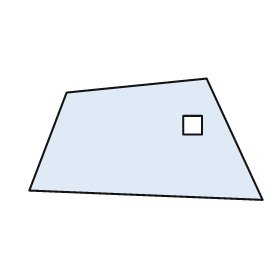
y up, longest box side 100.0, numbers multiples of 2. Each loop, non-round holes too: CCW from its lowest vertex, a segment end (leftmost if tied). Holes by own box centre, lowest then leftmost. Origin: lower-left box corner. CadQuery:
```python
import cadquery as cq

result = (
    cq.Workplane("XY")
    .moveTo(100.0, 0.0)
    .lineTo(76.0, 52.0)
    .lineTo(16.0, 46.0)
    .lineTo(0.0, 4.0)
    .close()
    .moveTo(66.0, 28.0)
    .lineTo(74.0, 28.0)
    .lineTo(74.0, 36.0)
    .lineTo(66.0, 36.0)
    .close()
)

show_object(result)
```